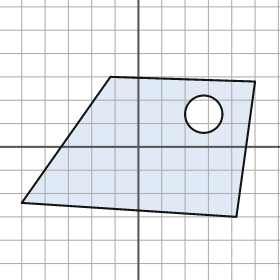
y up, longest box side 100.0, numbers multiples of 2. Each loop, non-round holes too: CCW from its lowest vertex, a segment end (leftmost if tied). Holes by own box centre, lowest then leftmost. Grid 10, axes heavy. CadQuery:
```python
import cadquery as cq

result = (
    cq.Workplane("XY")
    .moveTo(42.0, -30.0)
    .lineTo(50.0, 28.0)
    .lineTo(-12.0, 30.0)
    .lineTo(-50.0, -24.0)
    .close()
    .moveTo(28.0, 14.0)
    .circle(8.0)
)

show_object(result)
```